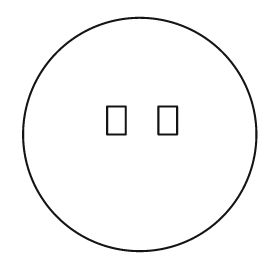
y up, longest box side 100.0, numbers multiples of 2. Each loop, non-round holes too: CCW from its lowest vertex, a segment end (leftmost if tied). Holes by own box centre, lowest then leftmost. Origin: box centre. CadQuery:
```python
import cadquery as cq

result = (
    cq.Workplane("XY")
    .moveTo(0.0, 0.0)
    .circle(50.0)
    .moveTo(-14.0, 0.0)
    .lineTo(-6.0, 0.0)
    .lineTo(-6.0, 12.0)
    .lineTo(-14.0, 12.0)
    .close()
    .moveTo(8.0, 0.0)
    .lineTo(16.0, 0.0)
    .lineTo(16.0, 12.0)
    .lineTo(8.0, 12.0)
    .close()
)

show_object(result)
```